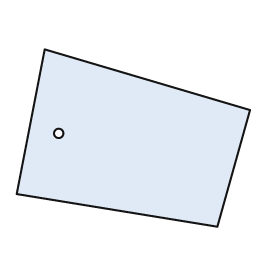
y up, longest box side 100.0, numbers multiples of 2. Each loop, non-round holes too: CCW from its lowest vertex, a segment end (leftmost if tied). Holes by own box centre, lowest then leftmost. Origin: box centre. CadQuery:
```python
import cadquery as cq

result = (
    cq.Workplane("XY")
    .moveTo(36.0, -38.0)
    .lineTo(50.0, 12.0)
    .lineTo(-38.0, 38.0)
    .lineTo(-50.0, -24.0)
    .close()
    .moveTo(-32.0, 2.0)
    .circle(2.0)
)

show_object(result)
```